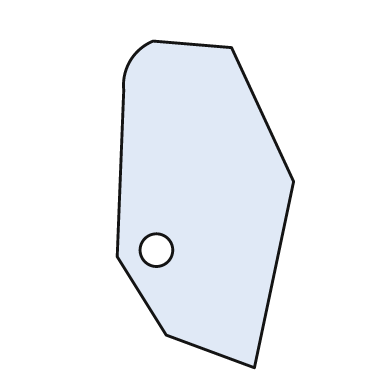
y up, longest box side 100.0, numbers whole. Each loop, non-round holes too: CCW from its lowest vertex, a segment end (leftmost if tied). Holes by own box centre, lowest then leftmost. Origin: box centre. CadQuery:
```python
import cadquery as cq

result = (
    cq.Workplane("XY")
    .moveTo(15.0, -50.0)
    .lineTo(27.0, 7.0)
    .lineTo(8.0, 48.0)
    .lineTo(-16.0, 50.0)
    .threePointArc((-23.0, 44.0), (-25.0, 35.0))
    .lineTo(-27.0, -16.0)
    .lineTo(-12.0, -40.0)
    .close()
    .moveTo(-15.0, -14.0)
    .circle(5.0)
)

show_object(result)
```